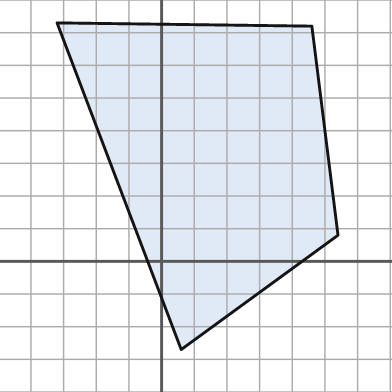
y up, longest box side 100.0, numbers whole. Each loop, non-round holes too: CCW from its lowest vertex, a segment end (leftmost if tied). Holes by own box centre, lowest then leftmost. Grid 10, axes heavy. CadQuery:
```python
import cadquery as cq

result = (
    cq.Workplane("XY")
    .moveTo(6.0, -27.0)
    .lineTo(54.0, 8.0)
    .lineTo(46.0, 72.0)
    .lineTo(-32.0, 73.0)
    .close()
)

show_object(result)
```